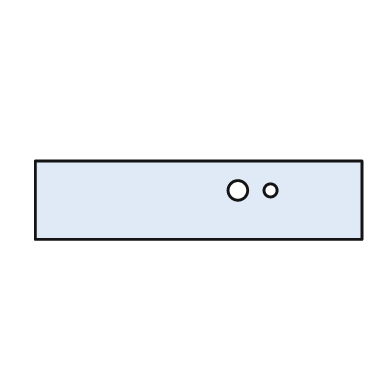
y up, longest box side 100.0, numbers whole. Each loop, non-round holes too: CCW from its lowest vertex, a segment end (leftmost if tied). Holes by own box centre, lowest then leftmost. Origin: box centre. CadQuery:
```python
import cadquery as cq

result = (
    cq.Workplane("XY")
    .moveTo(-50.0, -12.0)
    .lineTo(50.0, -12.0)
    .lineTo(50.0, 12.0)
    .lineTo(-50.0, 12.0)
    .close()
    .moveTo(12.0, 3.0)
    .circle(3.0)
    .moveTo(22.0, 3.0)
    .circle(2.0)
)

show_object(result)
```